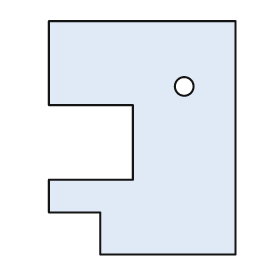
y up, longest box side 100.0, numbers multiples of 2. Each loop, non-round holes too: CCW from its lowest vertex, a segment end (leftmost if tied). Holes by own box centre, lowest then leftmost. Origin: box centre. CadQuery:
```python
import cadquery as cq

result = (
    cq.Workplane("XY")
    .moveTo(-18.0, -50.0)
    .lineTo(40.0, -50.0)
    .lineTo(40.0, 50.0)
    .lineTo(-40.0, 50.0)
    .lineTo(-40.0, 14.0)
    .lineTo(-4.0, 14.0)
    .lineTo(-4.0, -18.0)
    .lineTo(-40.0, -18.0)
    .lineTo(-40.0, -32.0)
    .lineTo(-18.0, -32.0)
    .close()
    .moveTo(18.0, 22.0)
    .circle(4.0)
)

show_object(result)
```